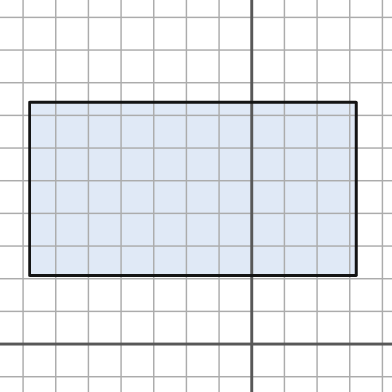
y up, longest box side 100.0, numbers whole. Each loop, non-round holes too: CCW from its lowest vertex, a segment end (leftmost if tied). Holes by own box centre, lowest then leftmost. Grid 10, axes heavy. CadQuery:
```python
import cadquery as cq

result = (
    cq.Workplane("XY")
    .moveTo(-68.0, 21.0)
    .lineTo(32.0, 21.0)
    .lineTo(32.0, 74.0)
    .lineTo(-68.0, 74.0)
    .close()
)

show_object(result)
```